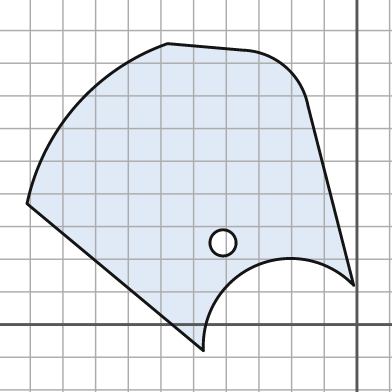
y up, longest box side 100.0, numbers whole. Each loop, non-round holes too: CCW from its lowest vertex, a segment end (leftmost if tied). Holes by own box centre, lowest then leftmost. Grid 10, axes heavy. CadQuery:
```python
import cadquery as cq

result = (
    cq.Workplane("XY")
    .moveTo(-47.0, -8.0)
    .threePointArc((-31.0, 18.0), (-1.0, 12.0))
    .lineTo(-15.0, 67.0)
    .threePointArc((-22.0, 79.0), (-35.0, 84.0))
    .lineTo(-58.0, 86.0)
    .threePointArc((-86.0, 67.0), (-101.0, 37.0))
    .close()
    .moveTo(-41.0, 25.0)
    .circle(4.0)
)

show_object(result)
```